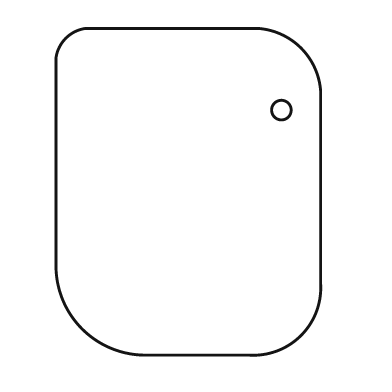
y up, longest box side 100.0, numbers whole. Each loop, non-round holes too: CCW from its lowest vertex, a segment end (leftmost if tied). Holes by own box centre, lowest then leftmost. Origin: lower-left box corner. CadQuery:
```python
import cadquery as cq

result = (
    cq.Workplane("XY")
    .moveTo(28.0, 0.0)
    .lineTo(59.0, 0.0)
    .threePointArc((75.0, 6.0), (81.0, 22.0))
    .lineTo(81.0, 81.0)
    .threePointArc((75.0, 94.0), (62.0, 100.0))
    .lineTo(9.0, 100.0)
    .threePointArc((3.0, 97.0), (0.0, 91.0))
    .lineTo(0.0, 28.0)
    .threePointArc((8.0, 8.0), (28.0, 0.0))
    .close()
    .moveTo(69.0, 75.0)
    .circle(3.0)
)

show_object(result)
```